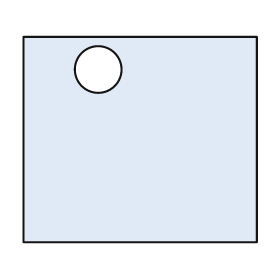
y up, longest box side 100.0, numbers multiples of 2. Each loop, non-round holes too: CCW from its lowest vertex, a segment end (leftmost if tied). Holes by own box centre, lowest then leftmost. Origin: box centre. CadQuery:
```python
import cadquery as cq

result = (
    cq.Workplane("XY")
    .moveTo(-50.0, -44.0)
    .lineTo(50.0, -44.0)
    .lineTo(50.0, 44.0)
    .lineTo(-50.0, 44.0)
    .close()
    .moveTo(-18.0, 30.0)
    .circle(10.0)
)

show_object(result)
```